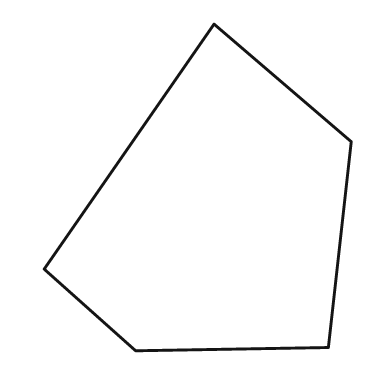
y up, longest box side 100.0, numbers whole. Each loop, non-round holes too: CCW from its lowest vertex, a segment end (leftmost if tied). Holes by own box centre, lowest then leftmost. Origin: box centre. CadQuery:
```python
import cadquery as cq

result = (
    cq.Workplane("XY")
    .moveTo(-19.0, -50.0)
    .lineTo(40.0, -49.0)
    .lineTo(47.0, 14.0)
    .lineTo(5.0, 50.0)
    .lineTo(-47.0, -25.0)
    .close()
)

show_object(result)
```